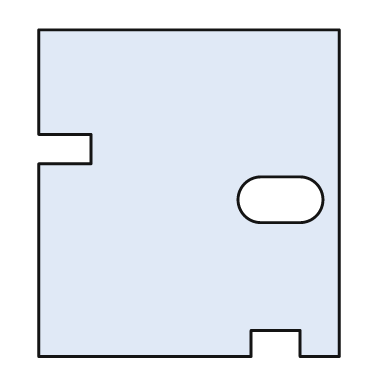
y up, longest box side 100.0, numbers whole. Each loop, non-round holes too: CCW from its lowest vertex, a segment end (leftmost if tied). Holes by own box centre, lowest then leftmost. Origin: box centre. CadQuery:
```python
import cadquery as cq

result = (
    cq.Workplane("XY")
    .moveTo(-46.0, -50.0)
    .lineTo(19.0, -50.0)
    .lineTo(19.0, -42.0)
    .lineTo(34.0, -42.0)
    .lineTo(34.0, -50.0)
    .lineTo(46.0, -50.0)
    .lineTo(46.0, 50.0)
    .lineTo(-46.0, 50.0)
    .lineTo(-46.0, 18.0)
    .lineTo(-30.0, 18.0)
    .lineTo(-30.0, 9.0)
    .lineTo(-46.0, 9.0)
    .close()
    .moveTo(22.0, -9.0)
    .lineTo(34.0, -9.0)
    .threePointArc((41.0, -2.0), (34.0, 5.0))
    .lineTo(22.0, 5.0)
    .threePointArc((15.0, -2.0), (22.0, -9.0))
    .close()
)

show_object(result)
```